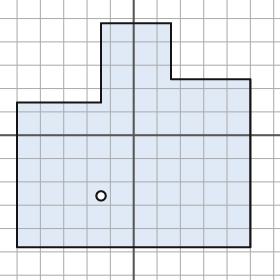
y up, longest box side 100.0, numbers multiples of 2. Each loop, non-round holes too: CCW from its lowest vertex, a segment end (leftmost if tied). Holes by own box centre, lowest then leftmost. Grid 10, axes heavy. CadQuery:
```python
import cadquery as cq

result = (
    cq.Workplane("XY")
    .moveTo(-50.0, -48.0)
    .lineTo(50.0, -48.0)
    .lineTo(50.0, 24.0)
    .lineTo(16.0, 24.0)
    .lineTo(16.0, 48.0)
    .lineTo(-14.0, 48.0)
    .lineTo(-14.0, 14.0)
    .lineTo(-50.0, 14.0)
    .close()
    .moveTo(-14.0, -26.0)
    .circle(2.0)
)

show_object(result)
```